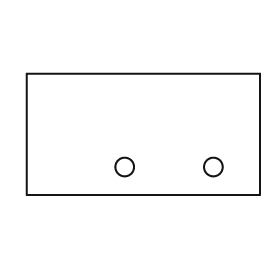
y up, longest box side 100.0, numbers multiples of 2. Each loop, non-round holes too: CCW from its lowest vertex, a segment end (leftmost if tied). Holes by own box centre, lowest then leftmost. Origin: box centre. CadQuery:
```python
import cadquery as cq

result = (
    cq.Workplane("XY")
    .moveTo(-50.0, -26.0)
    .lineTo(50.0, -26.0)
    .lineTo(50.0, 26.0)
    .lineTo(-50.0, 26.0)
    .close()
    .moveTo(-8.0, -14.0)
    .circle(4.0)
    .moveTo(30.0, -14.0)
    .circle(4.0)
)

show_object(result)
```